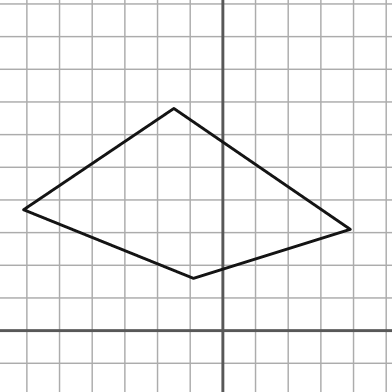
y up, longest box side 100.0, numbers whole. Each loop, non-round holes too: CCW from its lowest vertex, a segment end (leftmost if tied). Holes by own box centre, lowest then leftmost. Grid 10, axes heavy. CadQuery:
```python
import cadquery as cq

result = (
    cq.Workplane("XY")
    .moveTo(-9.0, 16.0)
    .lineTo(39.0, 31.0)
    .lineTo(-15.0, 68.0)
    .lineTo(-61.0, 37.0)
    .close()
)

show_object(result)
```